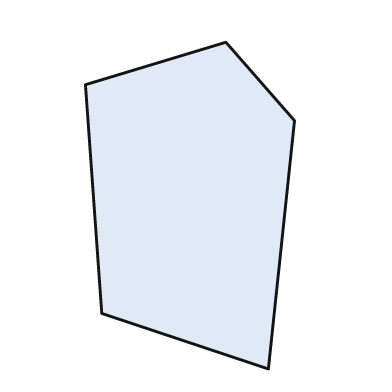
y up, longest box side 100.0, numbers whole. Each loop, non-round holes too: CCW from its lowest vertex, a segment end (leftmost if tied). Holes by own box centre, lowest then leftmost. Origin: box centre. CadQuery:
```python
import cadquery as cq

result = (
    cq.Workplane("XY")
    .moveTo(24.0, -50.0)
    .lineTo(32.0, 26.0)
    .lineTo(11.0, 50.0)
    .lineTo(-32.0, 37.0)
    .lineTo(-27.0, -33.0)
    .close()
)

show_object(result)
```